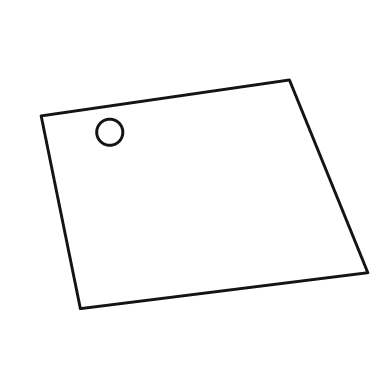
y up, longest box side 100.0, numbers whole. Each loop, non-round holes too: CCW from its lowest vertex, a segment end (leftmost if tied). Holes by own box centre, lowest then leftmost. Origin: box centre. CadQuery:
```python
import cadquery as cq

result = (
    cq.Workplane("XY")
    .moveTo(-38.0, -35.0)
    .lineTo(50.0, -24.0)
    .lineTo(26.0, 35.0)
    .lineTo(-50.0, 24.0)
    .close()
    .moveTo(-29.0, 19.0)
    .circle(4.0)
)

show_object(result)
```